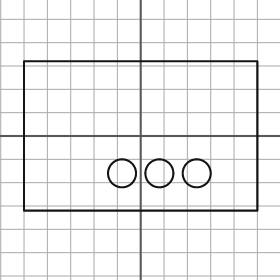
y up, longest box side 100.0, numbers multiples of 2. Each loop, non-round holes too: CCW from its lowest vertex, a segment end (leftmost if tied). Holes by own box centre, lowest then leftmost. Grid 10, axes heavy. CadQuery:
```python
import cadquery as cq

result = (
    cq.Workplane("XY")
    .moveTo(-50.0, -32.0)
    .lineTo(50.0, -32.0)
    .lineTo(50.0, 32.0)
    .lineTo(-50.0, 32.0)
    .close()
    .moveTo(-8.0, -16.0)
    .circle(6.0)
    .moveTo(8.0, -16.0)
    .circle(6.0)
    .moveTo(24.0, -16.0)
    .circle(6.0)
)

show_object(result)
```